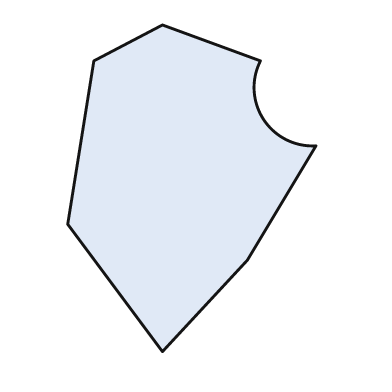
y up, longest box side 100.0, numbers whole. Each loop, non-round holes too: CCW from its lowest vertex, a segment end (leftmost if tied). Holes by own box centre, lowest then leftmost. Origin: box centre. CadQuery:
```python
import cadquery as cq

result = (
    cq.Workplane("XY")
    .moveTo(-9.0, -50.0)
    .lineTo(17.0, -22.0)
    .lineTo(38.0, 13.0)
    .threePointArc((22.0, 21.0), (21.0, 39.0))
    .lineTo(-9.0, 50.0)
    .lineTo(-30.0, 39.0)
    .lineTo(-38.0, -11.0)
    .close()
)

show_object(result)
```